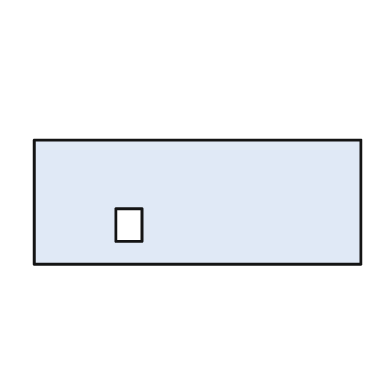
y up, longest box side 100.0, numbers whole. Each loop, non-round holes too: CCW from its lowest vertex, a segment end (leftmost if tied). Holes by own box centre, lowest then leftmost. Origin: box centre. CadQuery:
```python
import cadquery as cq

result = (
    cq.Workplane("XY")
    .moveTo(-50.0, -19.0)
    .lineTo(50.0, -19.0)
    .lineTo(50.0, 19.0)
    .lineTo(-50.0, 19.0)
    .close()
    .moveTo(-25.0, -12.0)
    .lineTo(-17.0, -12.0)
    .lineTo(-17.0, -2.0)
    .lineTo(-25.0, -2.0)
    .close()
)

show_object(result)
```